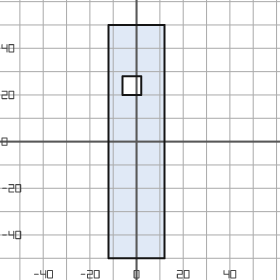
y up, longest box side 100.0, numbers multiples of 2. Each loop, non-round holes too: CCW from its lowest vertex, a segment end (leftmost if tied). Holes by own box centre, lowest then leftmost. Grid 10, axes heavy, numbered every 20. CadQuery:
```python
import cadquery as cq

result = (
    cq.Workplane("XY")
    .moveTo(-12.0, -50.0)
    .lineTo(12.0, -50.0)
    .lineTo(12.0, 50.0)
    .lineTo(-12.0, 50.0)
    .close()
    .moveTo(-6.0, 20.0)
    .lineTo(2.0, 20.0)
    .lineTo(2.0, 28.0)
    .lineTo(-6.0, 28.0)
    .close()
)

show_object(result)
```